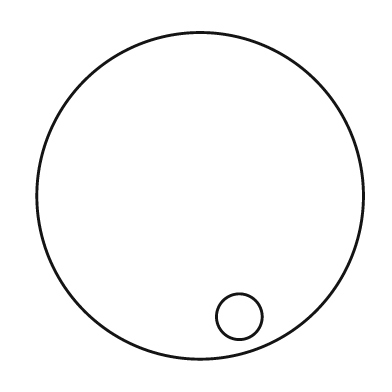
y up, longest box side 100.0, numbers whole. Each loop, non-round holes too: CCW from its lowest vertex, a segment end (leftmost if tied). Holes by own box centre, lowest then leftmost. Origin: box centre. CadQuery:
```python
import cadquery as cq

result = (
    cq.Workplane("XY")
    .moveTo(0.0, 0.0)
    .circle(50.0)
    .moveTo(12.0, -37.0)
    .circle(7.0)
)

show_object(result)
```